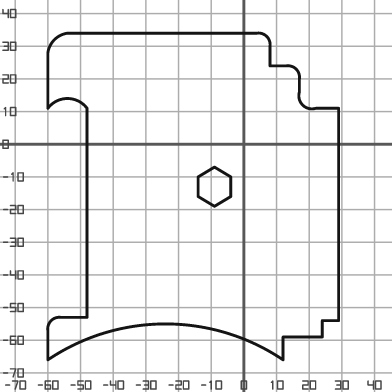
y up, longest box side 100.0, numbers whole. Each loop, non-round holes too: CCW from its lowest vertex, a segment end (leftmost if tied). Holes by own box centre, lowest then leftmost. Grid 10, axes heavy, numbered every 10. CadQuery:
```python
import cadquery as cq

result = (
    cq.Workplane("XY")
    .moveTo(-60.0, -66.0)
    .threePointArc((-24.0, -55.0), (12.0, -66.0))
    .lineTo(12.0, -59.0)
    .lineTo(24.0, -59.0)
    .lineTo(24.0, -54.0)
    .lineTo(29.0, -54.0)
    .lineTo(29.0, 11.0)
    .lineTo(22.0, 11.0)
    .threePointArc((18.0, 12.0), (17.0, 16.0))
    .lineTo(17.0, 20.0)
    .threePointArc((16.0, 23.0), (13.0, 24.0))
    .lineTo(8.0, 24.0)
    .lineTo(8.0, 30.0)
    .threePointArc((7.0, 33.0), (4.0, 34.0))
    .lineTo(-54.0, 34.0)
    .threePointArc((-58.0, 32.0), (-60.0, 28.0))
    .lineTo(-60.0, 11.0)
    .threePointArc((-54.0, 14.0), (-48.0, 11.0))
    .lineTo(-48.0, -53.0)
    .lineTo(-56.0, -53.0)
    .threePointArc((-59.0, -54.0), (-60.0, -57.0))
    .close()
    .moveTo(-9.0, -19.0)
    .lineTo(-4.0, -16.0)
    .lineTo(-4.0, -10.0)
    .lineTo(-9.0, -7.0)
    .lineTo(-14.0, -10.0)
    .lineTo(-14.0, -16.0)
    .close()
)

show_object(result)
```